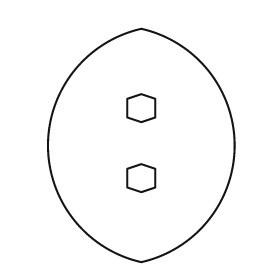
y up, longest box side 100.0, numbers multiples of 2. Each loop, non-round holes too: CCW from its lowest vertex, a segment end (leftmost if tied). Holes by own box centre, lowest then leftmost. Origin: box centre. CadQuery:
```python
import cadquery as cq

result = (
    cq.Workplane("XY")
    .moveTo(0.0, -50.0)
    .threePointArc((40.0, 0.0), (0.0, 50.0))
    .threePointArc((-40.0, 0.0), (0.0, -50.0))
    .close()
    .moveTo(0.0, -20.0)
    .lineTo(6.0, -18.0)
    .lineTo(6.0, -10.0)
    .lineTo(0.0, -8.0)
    .lineTo(-6.0, -10.0)
    .lineTo(-6.0, -18.0)
    .close()
    .moveTo(0.0, 10.0)
    .lineTo(6.0, 12.0)
    .lineTo(6.0, 20.0)
    .lineTo(0.0, 22.0)
    .lineTo(-6.0, 20.0)
    .lineTo(-6.0, 12.0)
    .close()
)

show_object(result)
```